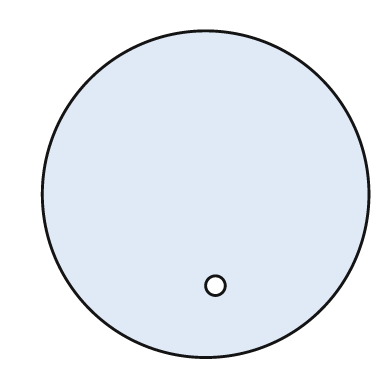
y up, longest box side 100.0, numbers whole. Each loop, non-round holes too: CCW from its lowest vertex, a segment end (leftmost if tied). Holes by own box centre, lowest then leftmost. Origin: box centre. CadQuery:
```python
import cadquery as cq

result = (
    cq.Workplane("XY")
    .moveTo(0.0, 0.0)
    .circle(50.0)
    .moveTo(3.0, -28.0)
    .circle(3.0)
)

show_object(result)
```